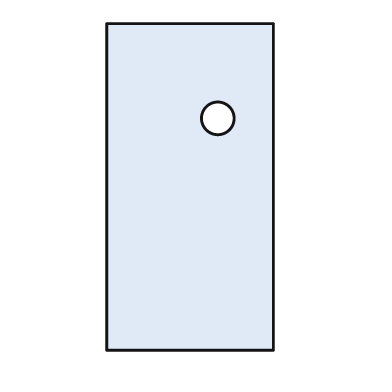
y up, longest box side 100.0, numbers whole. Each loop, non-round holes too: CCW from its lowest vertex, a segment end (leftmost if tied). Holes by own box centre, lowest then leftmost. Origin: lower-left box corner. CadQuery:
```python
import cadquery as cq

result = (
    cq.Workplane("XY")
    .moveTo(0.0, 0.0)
    .lineTo(51.0, 0.0)
    .lineTo(51.0, 100.0)
    .lineTo(0.0, 100.0)
    .close()
    .moveTo(34.0, 71.0)
    .circle(5.0)
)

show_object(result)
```